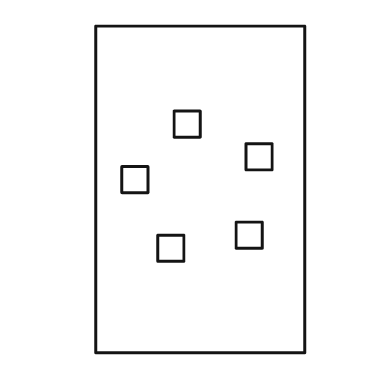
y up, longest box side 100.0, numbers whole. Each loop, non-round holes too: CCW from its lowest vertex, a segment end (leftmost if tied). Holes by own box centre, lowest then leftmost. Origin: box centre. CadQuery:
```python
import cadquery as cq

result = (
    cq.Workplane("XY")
    .moveTo(-32.0, -50.0)
    .lineTo(32.0, -50.0)
    .lineTo(32.0, 50.0)
    .lineTo(-32.0, 50.0)
    .close()
    .moveTo(-13.0, -22.0)
    .lineTo(-5.0, -22.0)
    .lineTo(-5.0, -14.0)
    .lineTo(-13.0, -14.0)
    .close()
    .moveTo(11.0, -18.0)
    .lineTo(19.0, -18.0)
    .lineTo(19.0, -10.0)
    .lineTo(11.0, -10.0)
    .close()
    .moveTo(-24.0, -1.0)
    .lineTo(-16.0, -1.0)
    .lineTo(-16.0, 7.0)
    .lineTo(-24.0, 7.0)
    .close()
    .moveTo(14.0, 6.0)
    .lineTo(22.0, 6.0)
    .lineTo(22.0, 14.0)
    .lineTo(14.0, 14.0)
    .close()
    .moveTo(-8.0, 16.0)
    .lineTo(0.0, 16.0)
    .lineTo(0.0, 24.0)
    .lineTo(-8.0, 24.0)
    .close()
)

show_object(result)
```